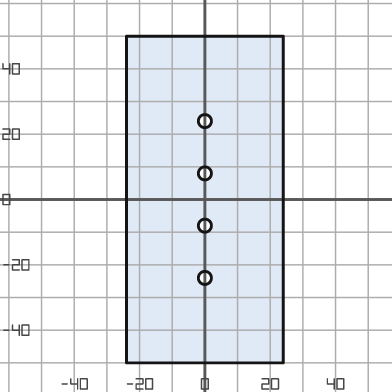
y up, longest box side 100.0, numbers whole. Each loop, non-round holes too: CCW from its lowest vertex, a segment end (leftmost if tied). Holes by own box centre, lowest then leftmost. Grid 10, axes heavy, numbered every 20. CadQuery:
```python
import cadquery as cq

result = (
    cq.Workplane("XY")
    .moveTo(-24.0, -50.0)
    .lineTo(24.0, -50.0)
    .lineTo(24.0, 50.0)
    .lineTo(-24.0, 50.0)
    .close()
    .moveTo(0.0, -24.0)
    .circle(2.0)
    .moveTo(0.0, -8.0)
    .circle(2.0)
    .moveTo(0.0, 8.0)
    .circle(2.0)
    .moveTo(0.0, 24.0)
    .circle(2.0)
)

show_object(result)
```